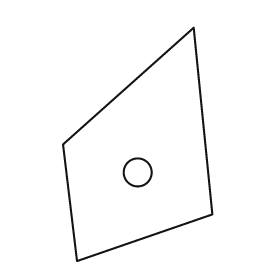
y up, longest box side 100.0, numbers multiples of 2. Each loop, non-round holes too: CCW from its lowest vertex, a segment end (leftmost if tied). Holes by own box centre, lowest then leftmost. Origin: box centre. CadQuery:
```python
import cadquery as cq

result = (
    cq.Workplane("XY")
    .moveTo(-26.0, -50.0)
    .lineTo(32.0, -30.0)
    .lineTo(24.0, 50.0)
    .lineTo(-32.0, 0.0)
    .close()
    .moveTo(0.0, -12.0)
    .circle(6.0)
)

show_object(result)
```